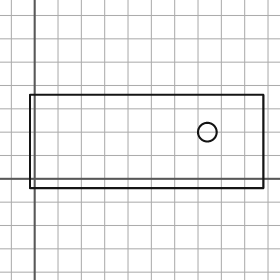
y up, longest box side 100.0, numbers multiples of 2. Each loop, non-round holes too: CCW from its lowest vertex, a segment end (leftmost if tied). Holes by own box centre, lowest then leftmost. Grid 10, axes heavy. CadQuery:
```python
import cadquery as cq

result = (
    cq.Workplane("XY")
    .moveTo(-2.0, -4.0)
    .lineTo(98.0, -4.0)
    .lineTo(98.0, 36.0)
    .lineTo(-2.0, 36.0)
    .close()
    .moveTo(74.0, 20.0)
    .circle(4.0)
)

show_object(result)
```